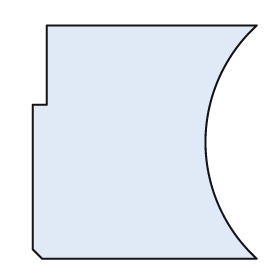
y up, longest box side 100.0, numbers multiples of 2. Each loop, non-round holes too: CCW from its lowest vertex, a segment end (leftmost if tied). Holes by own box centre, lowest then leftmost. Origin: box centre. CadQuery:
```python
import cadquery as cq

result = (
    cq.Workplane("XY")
    .moveTo(-44.0, -50.0)
    .lineTo(48.0, -50.0)
    .threePointArc((26.0, 0.0), (48.0, 50.0))
    .lineTo(-42.0, 50.0)
    .lineTo(-42.0, 16.0)
    .lineTo(-48.0, 16.0)
    .lineTo(-48.0, -46.0)
    .close()
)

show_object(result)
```